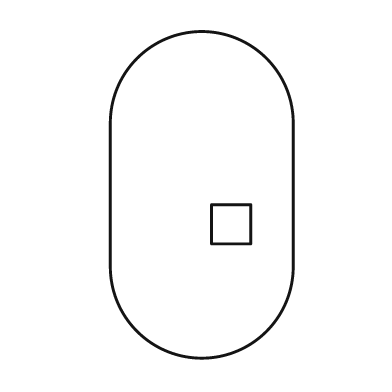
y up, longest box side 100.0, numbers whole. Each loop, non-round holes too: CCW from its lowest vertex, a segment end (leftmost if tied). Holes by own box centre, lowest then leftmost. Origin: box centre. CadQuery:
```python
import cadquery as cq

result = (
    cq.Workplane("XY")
    .moveTo(-28.0, -22.0)
    .threePointArc((0.0, -50.0), (28.0, -22.0))
    .lineTo(28.0, 22.0)
    .threePointArc((0.0, 50.0), (-28.0, 22.0))
    .close()
    .moveTo(3.0, -15.0)
    .lineTo(15.0, -15.0)
    .lineTo(15.0, -3.0)
    .lineTo(3.0, -3.0)
    .close()
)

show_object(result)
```